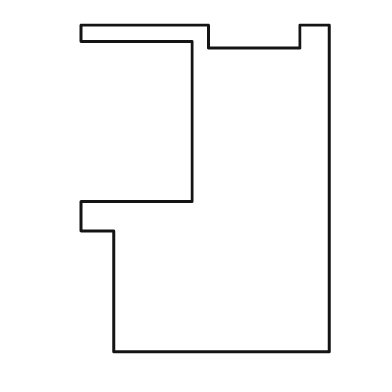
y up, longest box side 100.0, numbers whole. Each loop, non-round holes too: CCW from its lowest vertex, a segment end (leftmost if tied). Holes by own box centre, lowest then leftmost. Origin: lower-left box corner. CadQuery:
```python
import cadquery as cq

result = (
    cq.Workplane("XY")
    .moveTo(10.0, 0.0)
    .lineTo(76.0, 0.0)
    .lineTo(76.0, 100.0)
    .lineTo(67.0, 100.0)
    .lineTo(67.0, 93.0)
    .lineTo(39.0, 93.0)
    .lineTo(39.0, 100.0)
    .lineTo(0.0, 100.0)
    .lineTo(0.0, 95.0)
    .lineTo(34.0, 95.0)
    .lineTo(34.0, 46.0)
    .lineTo(0.0, 46.0)
    .lineTo(0.0, 37.0)
    .lineTo(10.0, 37.0)
    .close()
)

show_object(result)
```